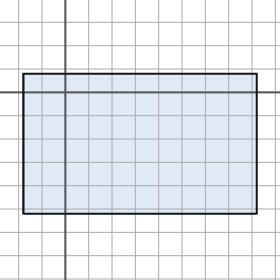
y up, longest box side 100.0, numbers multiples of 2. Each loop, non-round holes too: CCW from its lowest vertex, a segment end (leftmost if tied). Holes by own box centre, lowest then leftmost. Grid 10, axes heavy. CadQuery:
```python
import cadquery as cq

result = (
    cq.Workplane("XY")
    .moveTo(-18.0, -52.0)
    .lineTo(82.0, -52.0)
    .lineTo(82.0, 8.0)
    .lineTo(-18.0, 8.0)
    .close()
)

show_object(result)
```